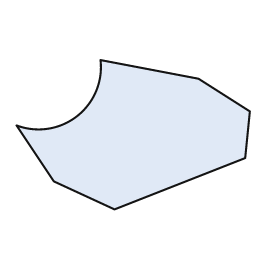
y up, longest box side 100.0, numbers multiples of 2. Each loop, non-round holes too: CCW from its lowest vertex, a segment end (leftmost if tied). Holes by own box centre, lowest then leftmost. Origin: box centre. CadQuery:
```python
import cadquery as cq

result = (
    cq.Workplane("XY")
    .moveTo(-8.0, -32.0)
    .lineTo(48.0, -10.0)
    .lineTo(50.0, 10.0)
    .lineTo(28.0, 24.0)
    .lineTo(-14.0, 32.0)
    .threePointArc((-24.0, 8.0), (-50.0, 4.0))
    .lineTo(-34.0, -20.0)
    .close()
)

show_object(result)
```